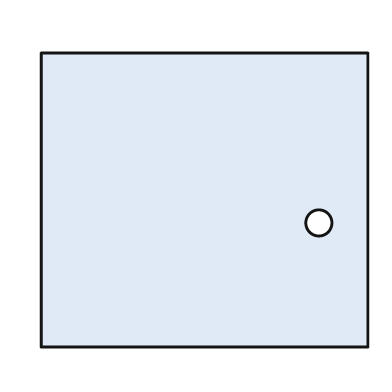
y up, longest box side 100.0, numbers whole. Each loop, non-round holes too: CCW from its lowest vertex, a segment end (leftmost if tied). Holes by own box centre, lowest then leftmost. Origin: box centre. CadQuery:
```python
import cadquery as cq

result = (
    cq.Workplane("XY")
    .moveTo(-50.0, -45.0)
    .lineTo(50.0, -45.0)
    .lineTo(50.0, 45.0)
    .lineTo(-50.0, 45.0)
    .close()
    .moveTo(35.0, -7.0)
    .circle(4.0)
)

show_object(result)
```